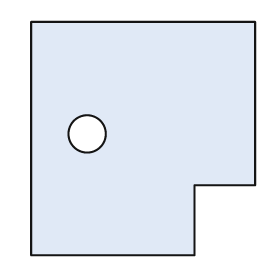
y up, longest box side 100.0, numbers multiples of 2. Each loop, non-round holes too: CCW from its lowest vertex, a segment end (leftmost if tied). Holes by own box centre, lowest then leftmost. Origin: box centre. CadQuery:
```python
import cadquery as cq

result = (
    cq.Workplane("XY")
    .moveTo(-48.0, -50.0)
    .lineTo(22.0, -50.0)
    .lineTo(22.0, -20.0)
    .lineTo(48.0, -20.0)
    .lineTo(48.0, 50.0)
    .lineTo(-48.0, 50.0)
    .close()
    .moveTo(-24.0, 2.0)
    .circle(8.0)
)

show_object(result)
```